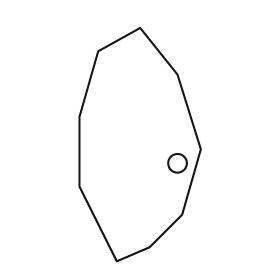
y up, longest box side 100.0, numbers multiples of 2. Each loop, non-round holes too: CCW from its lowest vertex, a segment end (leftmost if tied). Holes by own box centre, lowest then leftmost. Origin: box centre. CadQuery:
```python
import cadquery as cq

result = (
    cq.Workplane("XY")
    .moveTo(-10.0, -50.0)
    .lineTo(4.0, -44.0)
    .lineTo(18.0, -30.0)
    .lineTo(26.0, -2.0)
    .lineTo(16.0, 30.0)
    .lineTo(0.0, 50.0)
    .lineTo(-18.0, 40.0)
    .lineTo(-26.0, 12.0)
    .lineTo(-26.0, -18.0)
    .close()
    .moveTo(16.0, -8.0)
    .circle(4.0)
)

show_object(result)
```